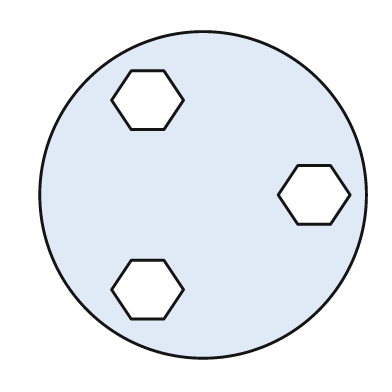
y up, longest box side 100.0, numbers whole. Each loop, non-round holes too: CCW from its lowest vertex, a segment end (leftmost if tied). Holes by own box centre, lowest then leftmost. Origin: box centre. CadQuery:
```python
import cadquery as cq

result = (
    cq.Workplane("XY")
    .moveTo(0.0, 0.0)
    .circle(50.0)
    .moveTo(-22.0, -38.0)
    .lineTo(-12.0, -38.0)
    .lineTo(-6.0, -29.0)
    .lineTo(-12.0, -20.0)
    .lineTo(-22.0, -20.0)
    .lineTo(-28.0, -29.0)
    .close()
    .moveTo(29.0, -9.0)
    .lineTo(39.0, -9.0)
    .lineTo(45.0, 0.0)
    .lineTo(39.0, 9.0)
    .lineTo(29.0, 9.0)
    .lineTo(23.0, 0.0)
    .close()
    .moveTo(-22.0, 20.0)
    .lineTo(-12.0, 20.0)
    .lineTo(-6.0, 29.0)
    .lineTo(-12.0, 38.0)
    .lineTo(-22.0, 38.0)
    .lineTo(-28.0, 29.0)
    .close()
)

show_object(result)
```